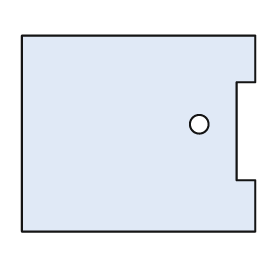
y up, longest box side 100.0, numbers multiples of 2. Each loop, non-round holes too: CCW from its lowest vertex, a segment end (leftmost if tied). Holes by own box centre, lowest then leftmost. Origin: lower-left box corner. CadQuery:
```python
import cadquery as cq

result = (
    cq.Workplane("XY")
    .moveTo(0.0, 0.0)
    .lineTo(100.0, 0.0)
    .lineTo(100.0, 22.0)
    .lineTo(92.0, 22.0)
    .lineTo(92.0, 64.0)
    .lineTo(100.0, 64.0)
    .lineTo(100.0, 84.0)
    .lineTo(0.0, 84.0)
    .close()
    .moveTo(76.0, 46.0)
    .circle(4.0)
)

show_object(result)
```